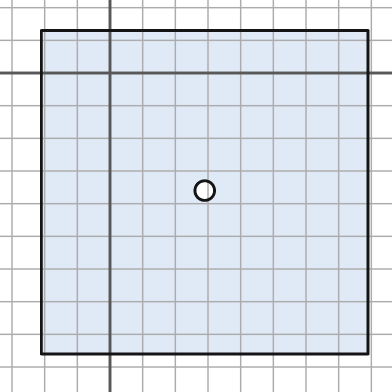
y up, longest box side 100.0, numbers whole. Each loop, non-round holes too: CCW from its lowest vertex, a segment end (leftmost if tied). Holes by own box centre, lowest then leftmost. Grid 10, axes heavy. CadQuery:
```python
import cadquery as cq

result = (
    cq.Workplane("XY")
    .moveTo(-21.0, -86.0)
    .lineTo(79.0, -86.0)
    .lineTo(79.0, 13.0)
    .lineTo(-21.0, 13.0)
    .close()
    .moveTo(29.0, -36.0)
    .circle(3.0)
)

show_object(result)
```